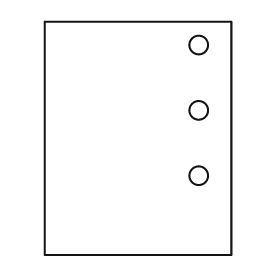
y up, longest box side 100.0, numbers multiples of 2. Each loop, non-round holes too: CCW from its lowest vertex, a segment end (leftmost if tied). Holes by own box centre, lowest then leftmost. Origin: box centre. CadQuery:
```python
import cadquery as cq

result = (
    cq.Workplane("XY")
    .moveTo(-40.0, -50.0)
    .lineTo(40.0, -50.0)
    .lineTo(40.0, 50.0)
    .lineTo(-40.0, 50.0)
    .close()
    .moveTo(26.0, -16.0)
    .circle(4.0)
    .moveTo(26.0, 12.0)
    .circle(4.0)
    .moveTo(26.0, 40.0)
    .circle(4.0)
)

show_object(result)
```